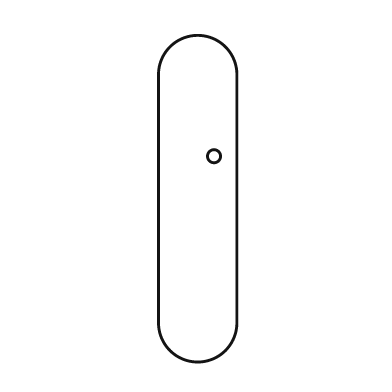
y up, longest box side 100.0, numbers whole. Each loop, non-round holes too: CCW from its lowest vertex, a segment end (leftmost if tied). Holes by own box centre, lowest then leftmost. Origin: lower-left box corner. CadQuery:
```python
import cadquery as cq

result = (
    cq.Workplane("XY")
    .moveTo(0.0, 12.0)
    .threePointArc((12.0, 0.0), (24.0, 12.0))
    .lineTo(24.0, 88.0)
    .threePointArc((12.0, 100.0), (0.0, 88.0))
    .close()
    .moveTo(17.0, 63.0)
    .circle(2.0)
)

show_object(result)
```